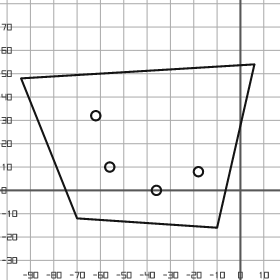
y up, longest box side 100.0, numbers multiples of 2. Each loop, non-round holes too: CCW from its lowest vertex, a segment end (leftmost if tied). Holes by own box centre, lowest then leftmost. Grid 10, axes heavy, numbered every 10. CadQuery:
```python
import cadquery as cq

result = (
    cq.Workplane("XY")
    .moveTo(-10.0, -16.0)
    .lineTo(6.0, 54.0)
    .lineTo(-94.0, 48.0)
    .lineTo(-70.0, -12.0)
    .close()
    .moveTo(-36.0, 0.0)
    .circle(2.0)
    .moveTo(-18.0, 8.0)
    .circle(2.0)
    .moveTo(-56.0, 10.0)
    .circle(2.0)
    .moveTo(-62.0, 32.0)
    .circle(2.0)
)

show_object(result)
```